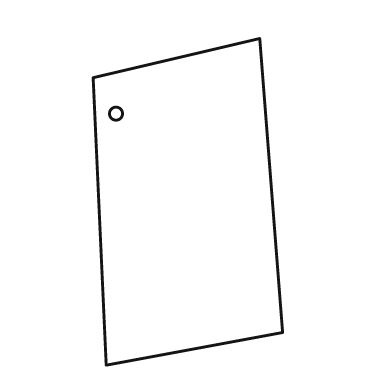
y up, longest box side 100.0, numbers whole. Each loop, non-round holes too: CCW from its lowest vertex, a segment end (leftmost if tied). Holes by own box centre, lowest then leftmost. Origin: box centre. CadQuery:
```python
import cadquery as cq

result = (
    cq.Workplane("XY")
    .moveTo(-25.0, -50.0)
    .lineTo(29.0, -40.0)
    .lineTo(22.0, 50.0)
    .lineTo(-29.0, 38.0)
    .close()
    .moveTo(-22.0, 27.0)
    .circle(2.0)
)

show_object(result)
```